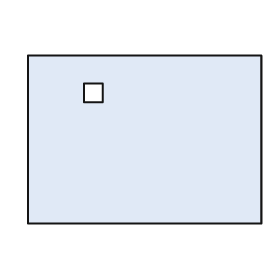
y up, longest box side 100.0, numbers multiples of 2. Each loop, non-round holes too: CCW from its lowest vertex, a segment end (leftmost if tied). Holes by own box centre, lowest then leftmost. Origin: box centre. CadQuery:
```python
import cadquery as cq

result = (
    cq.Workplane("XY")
    .moveTo(-50.0, -36.0)
    .lineTo(50.0, -36.0)
    .lineTo(50.0, 36.0)
    .lineTo(-50.0, 36.0)
    .close()
    .moveTo(-26.0, 16.0)
    .lineTo(-18.0, 16.0)
    .lineTo(-18.0, 24.0)
    .lineTo(-26.0, 24.0)
    .close()
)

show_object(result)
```